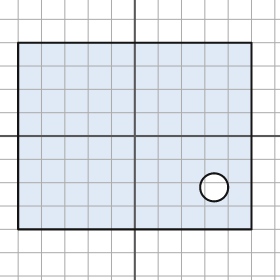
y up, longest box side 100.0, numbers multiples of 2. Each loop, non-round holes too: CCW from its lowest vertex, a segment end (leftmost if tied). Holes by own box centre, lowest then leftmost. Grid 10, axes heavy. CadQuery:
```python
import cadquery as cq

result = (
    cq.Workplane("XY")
    .moveTo(-50.0, -40.0)
    .lineTo(50.0, -40.0)
    .lineTo(50.0, 40.0)
    .lineTo(-50.0, 40.0)
    .close()
    .moveTo(34.0, -22.0)
    .circle(6.0)
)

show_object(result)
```